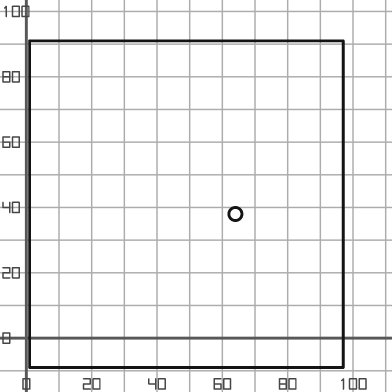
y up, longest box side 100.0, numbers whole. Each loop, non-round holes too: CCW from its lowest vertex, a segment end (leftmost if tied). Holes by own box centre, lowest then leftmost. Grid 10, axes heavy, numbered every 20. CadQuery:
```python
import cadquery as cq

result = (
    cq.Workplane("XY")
    .moveTo(1.0, -9.0)
    .lineTo(97.0, -9.0)
    .lineTo(97.0, 91.0)
    .lineTo(1.0, 91.0)
    .close()
    .moveTo(64.0, 38.0)
    .circle(2.0)
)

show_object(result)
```